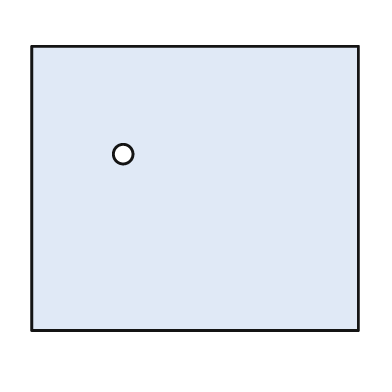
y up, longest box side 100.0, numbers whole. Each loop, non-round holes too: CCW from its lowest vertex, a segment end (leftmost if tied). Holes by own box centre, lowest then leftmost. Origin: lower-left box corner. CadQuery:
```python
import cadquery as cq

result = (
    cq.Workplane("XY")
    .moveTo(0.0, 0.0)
    .lineTo(100.0, 0.0)
    .lineTo(100.0, 87.0)
    .lineTo(0.0, 87.0)
    .close()
    .moveTo(28.0, 54.0)
    .circle(3.0)
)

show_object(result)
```